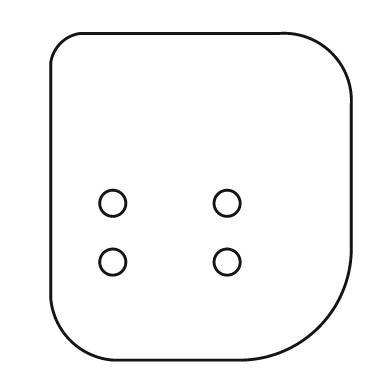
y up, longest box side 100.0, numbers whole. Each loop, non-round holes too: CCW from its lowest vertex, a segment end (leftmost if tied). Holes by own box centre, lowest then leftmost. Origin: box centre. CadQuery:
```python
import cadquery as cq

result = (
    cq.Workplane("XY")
    .moveTo(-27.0, -50.0)
    .lineTo(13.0, -50.0)
    .threePointArc((36.0, -40.0), (46.0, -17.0))
    .lineTo(46.0, 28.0)
    .threePointArc((40.0, 44.0), (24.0, 50.0))
    .lineTo(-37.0, 50.0)
    .threePointArc((-43.0, 47.0), (-46.0, 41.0))
    .lineTo(-46.0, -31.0)
    .threePointArc((-40.0, -44.0), (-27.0, -50.0))
    .close()
    .moveTo(-27.0, -20.0)
    .circle(4.0)
    .moveTo(8.0, -20.0)
    .circle(4.0)
    .moveTo(-27.0, -2.0)
    .circle(4.0)
    .moveTo(8.0, -2.0)
    .circle(4.0)
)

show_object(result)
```